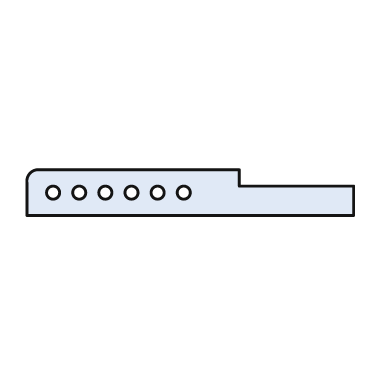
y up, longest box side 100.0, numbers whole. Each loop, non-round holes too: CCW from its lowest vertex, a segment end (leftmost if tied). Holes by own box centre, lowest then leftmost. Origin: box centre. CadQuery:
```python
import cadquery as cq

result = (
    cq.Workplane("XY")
    .moveTo(-50.0, -7.0)
    .lineTo(50.0, -7.0)
    .lineTo(50.0, 2.0)
    .lineTo(15.0, 2.0)
    .lineTo(15.0, 7.0)
    .lineTo(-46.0, 7.0)
    .threePointArc((-49.0, 6.0), (-50.0, 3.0))
    .close()
    .moveTo(-42.0, 0.0)
    .circle(2.0)
    .moveTo(-34.0, 0.0)
    .circle(2.0)
    .moveTo(-26.0, 0.0)
    .circle(2.0)
    .moveTo(-18.0, 0.0)
    .circle(2.0)
    .moveTo(-10.0, 0.0)
    .circle(2.0)
    .moveTo(-2.0, 0.0)
    .circle(2.0)
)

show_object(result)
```